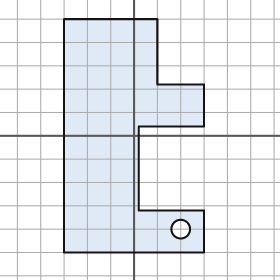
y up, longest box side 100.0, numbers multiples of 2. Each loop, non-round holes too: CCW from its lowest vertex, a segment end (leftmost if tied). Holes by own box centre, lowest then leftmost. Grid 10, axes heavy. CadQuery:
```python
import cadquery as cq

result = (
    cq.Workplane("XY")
    .moveTo(-30.0, -50.0)
    .lineTo(30.0, -50.0)
    .lineTo(30.0, -32.0)
    .lineTo(2.0, -32.0)
    .lineTo(2.0, 4.0)
    .lineTo(30.0, 4.0)
    .lineTo(30.0, 22.0)
    .lineTo(10.0, 22.0)
    .lineTo(10.0, 50.0)
    .lineTo(-30.0, 50.0)
    .close()
    .moveTo(20.0, -40.0)
    .circle(4.0)
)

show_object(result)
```